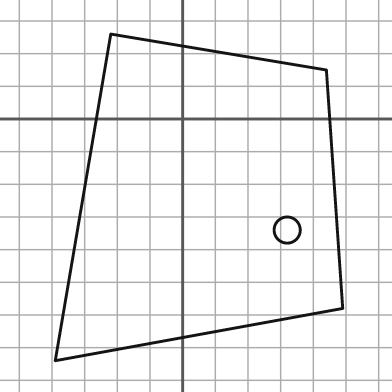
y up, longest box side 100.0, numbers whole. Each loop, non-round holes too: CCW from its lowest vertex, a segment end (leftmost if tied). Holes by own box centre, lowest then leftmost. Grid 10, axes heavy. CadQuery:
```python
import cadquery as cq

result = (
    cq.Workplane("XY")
    .moveTo(-39.0, -74.0)
    .lineTo(49.0, -58.0)
    .lineTo(44.0, 15.0)
    .lineTo(-22.0, 26.0)
    .close()
    .moveTo(32.0, -34.0)
    .circle(4.0)
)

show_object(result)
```